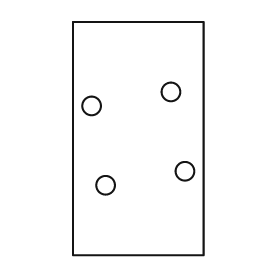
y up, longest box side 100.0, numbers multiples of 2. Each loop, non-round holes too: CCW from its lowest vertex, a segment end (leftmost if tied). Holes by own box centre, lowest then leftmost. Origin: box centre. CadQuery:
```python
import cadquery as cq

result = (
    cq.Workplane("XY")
    .moveTo(-28.0, -50.0)
    .lineTo(28.0, -50.0)
    .lineTo(28.0, 50.0)
    .lineTo(-28.0, 50.0)
    .close()
    .moveTo(-14.0, -20.0)
    .circle(4.0)
    .moveTo(20.0, -14.0)
    .circle(4.0)
    .moveTo(-20.0, 14.0)
    .circle(4.0)
    .moveTo(14.0, 20.0)
    .circle(4.0)
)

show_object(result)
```